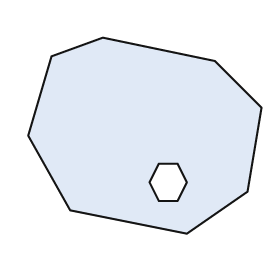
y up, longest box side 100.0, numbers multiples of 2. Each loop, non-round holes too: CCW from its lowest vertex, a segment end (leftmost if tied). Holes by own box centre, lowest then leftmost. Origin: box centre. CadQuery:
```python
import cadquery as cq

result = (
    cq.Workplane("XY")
    .moveTo(18.0, -42.0)
    .lineTo(44.0, -24.0)
    .lineTo(50.0, 12.0)
    .lineTo(30.0, 32.0)
    .lineTo(-18.0, 42.0)
    .lineTo(-40.0, 34.0)
    .lineTo(-50.0, 0.0)
    .lineTo(-32.0, -32.0)
    .close()
    .moveTo(6.0, -28.0)
    .lineTo(14.0, -28.0)
    .lineTo(18.0, -20.0)
    .lineTo(14.0, -12.0)
    .lineTo(6.0, -12.0)
    .lineTo(2.0, -20.0)
    .close()
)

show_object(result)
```